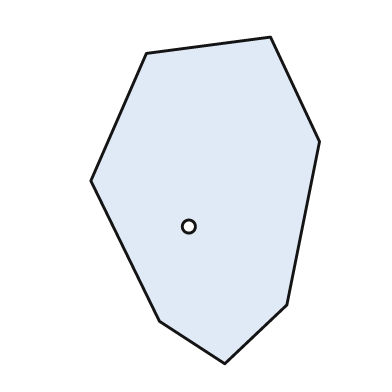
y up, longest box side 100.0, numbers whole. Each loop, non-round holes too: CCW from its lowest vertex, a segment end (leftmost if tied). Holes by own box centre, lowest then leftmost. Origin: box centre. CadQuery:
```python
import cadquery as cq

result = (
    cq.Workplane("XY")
    .moveTo(6.0, -50.0)
    .lineTo(25.0, -32.0)
    .lineTo(35.0, 18.0)
    .lineTo(20.0, 50.0)
    .lineTo(-18.0, 45.0)
    .lineTo(-35.0, 6.0)
    .lineTo(-14.0, -37.0)
    .close()
    .moveTo(-5.0, -8.0)
    .circle(2.0)
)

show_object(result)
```